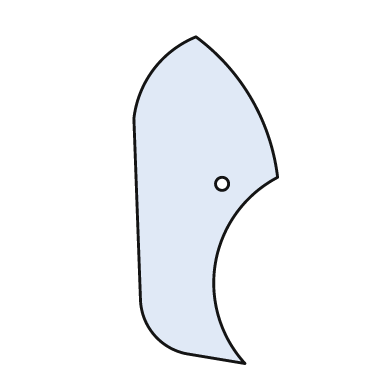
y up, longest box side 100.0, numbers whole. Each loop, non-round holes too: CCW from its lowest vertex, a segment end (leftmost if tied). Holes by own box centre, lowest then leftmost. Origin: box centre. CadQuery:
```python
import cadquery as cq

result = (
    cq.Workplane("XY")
    .moveTo(12.0, -50.0)
    .threePointArc((3.0, -19.0), (22.0, 7.0))
    .threePointArc((14.0, 31.0), (-3.0, 50.0))
    .threePointArc((-16.0, 40.0), (-22.0, 25.0))
    .lineTo(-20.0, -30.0)
    .threePointArc((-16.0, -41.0), (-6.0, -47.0))
    .close()
    .moveTo(5.0, 5.0)
    .circle(2.0)
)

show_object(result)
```